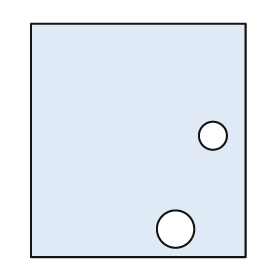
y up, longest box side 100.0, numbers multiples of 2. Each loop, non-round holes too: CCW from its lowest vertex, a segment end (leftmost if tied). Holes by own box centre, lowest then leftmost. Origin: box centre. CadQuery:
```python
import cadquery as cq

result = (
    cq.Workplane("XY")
    .moveTo(-46.0, -50.0)
    .lineTo(46.0, -50.0)
    .lineTo(46.0, 50.0)
    .lineTo(-46.0, 50.0)
    .close()
    .moveTo(16.0, -38.0)
    .circle(8.0)
    .moveTo(32.0, 2.0)
    .circle(6.0)
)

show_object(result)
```